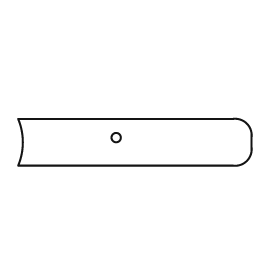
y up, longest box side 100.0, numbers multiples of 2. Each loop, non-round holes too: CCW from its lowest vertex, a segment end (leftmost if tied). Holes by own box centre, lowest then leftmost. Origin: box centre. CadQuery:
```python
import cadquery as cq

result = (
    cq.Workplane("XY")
    .moveTo(-50.0, -10.0)
    .lineTo(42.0, -10.0)
    .threePointArc((48.0, -8.0), (50.0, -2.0))
    .lineTo(50.0, 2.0)
    .threePointArc((48.0, 8.0), (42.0, 10.0))
    .lineTo(-50.0, 10.0)
    .threePointArc((-48.0, 0.0), (-50.0, -10.0))
    .close()
    .moveTo(-8.0, 2.0)
    .circle(2.0)
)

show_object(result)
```